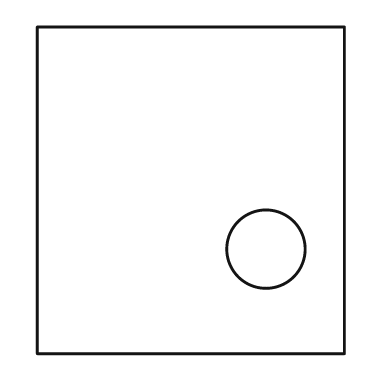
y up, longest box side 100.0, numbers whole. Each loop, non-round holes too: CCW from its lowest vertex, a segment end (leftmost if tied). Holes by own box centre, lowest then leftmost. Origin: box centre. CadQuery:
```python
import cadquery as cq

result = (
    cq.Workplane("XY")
    .moveTo(-47.0, -50.0)
    .lineTo(47.0, -50.0)
    .lineTo(47.0, 50.0)
    .lineTo(-47.0, 50.0)
    .close()
    .moveTo(23.0, -18.0)
    .circle(12.0)
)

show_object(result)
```